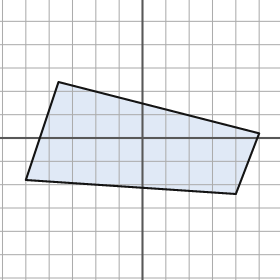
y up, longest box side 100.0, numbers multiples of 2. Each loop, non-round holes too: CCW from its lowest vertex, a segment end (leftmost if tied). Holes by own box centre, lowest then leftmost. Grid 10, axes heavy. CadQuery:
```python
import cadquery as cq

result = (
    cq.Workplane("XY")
    .moveTo(40.0, -24.0)
    .lineTo(50.0, 2.0)
    .lineTo(-36.0, 24.0)
    .lineTo(-50.0, -18.0)
    .close()
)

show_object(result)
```